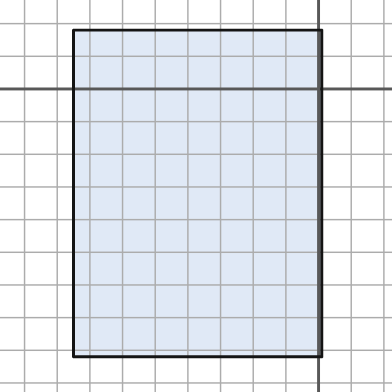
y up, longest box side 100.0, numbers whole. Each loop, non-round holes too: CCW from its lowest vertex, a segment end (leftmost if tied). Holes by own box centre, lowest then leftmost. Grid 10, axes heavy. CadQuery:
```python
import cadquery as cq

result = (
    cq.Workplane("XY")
    .moveTo(-75.0, -82.0)
    .lineTo(1.0, -82.0)
    .lineTo(1.0, 18.0)
    .lineTo(-75.0, 18.0)
    .close()
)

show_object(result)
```